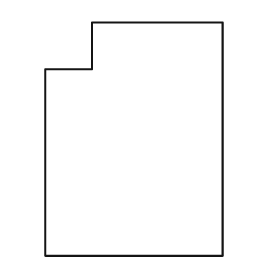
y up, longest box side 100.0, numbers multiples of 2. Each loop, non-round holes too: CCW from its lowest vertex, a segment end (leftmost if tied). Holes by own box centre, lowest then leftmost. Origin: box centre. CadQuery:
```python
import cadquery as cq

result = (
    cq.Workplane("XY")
    .moveTo(-38.0, -50.0)
    .lineTo(38.0, -50.0)
    .lineTo(38.0, 50.0)
    .lineTo(-18.0, 50.0)
    .lineTo(-18.0, 30.0)
    .lineTo(-38.0, 30.0)
    .close()
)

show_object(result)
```